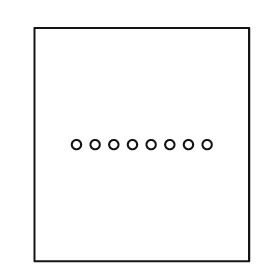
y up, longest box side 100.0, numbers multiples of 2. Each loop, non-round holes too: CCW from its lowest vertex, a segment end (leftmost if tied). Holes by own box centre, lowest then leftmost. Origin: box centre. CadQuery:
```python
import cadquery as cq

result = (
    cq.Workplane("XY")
    .moveTo(-46.0, -50.0)
    .lineTo(46.0, -50.0)
    .lineTo(46.0, 50.0)
    .lineTo(-46.0, 50.0)
    .close()
    .moveTo(-28.0, 0.0)
    .circle(2.0)
    .moveTo(-20.0, 0.0)
    .circle(2.0)
    .moveTo(-12.0, 0.0)
    .circle(2.0)
    .moveTo(-4.0, 0.0)
    .circle(2.0)
    .moveTo(4.0, 0.0)
    .circle(2.0)
    .moveTo(12.0, 0.0)
    .circle(2.0)
    .moveTo(20.0, 0.0)
    .circle(2.0)
    .moveTo(28.0, 0.0)
    .circle(2.0)
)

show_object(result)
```